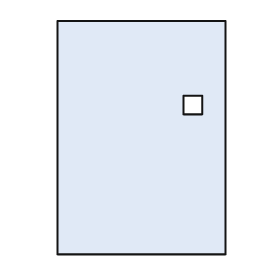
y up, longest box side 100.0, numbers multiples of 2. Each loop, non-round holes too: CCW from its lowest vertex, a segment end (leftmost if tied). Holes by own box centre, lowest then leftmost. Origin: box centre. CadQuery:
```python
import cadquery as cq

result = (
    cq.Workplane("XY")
    .moveTo(-36.0, -50.0)
    .lineTo(36.0, -50.0)
    .lineTo(36.0, 50.0)
    .lineTo(-36.0, 50.0)
    .close()
    .moveTo(18.0, 10.0)
    .lineTo(26.0, 10.0)
    .lineTo(26.0, 18.0)
    .lineTo(18.0, 18.0)
    .close()
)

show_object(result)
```